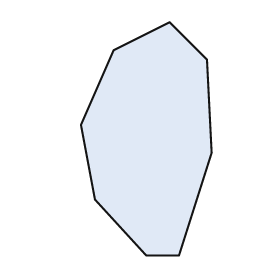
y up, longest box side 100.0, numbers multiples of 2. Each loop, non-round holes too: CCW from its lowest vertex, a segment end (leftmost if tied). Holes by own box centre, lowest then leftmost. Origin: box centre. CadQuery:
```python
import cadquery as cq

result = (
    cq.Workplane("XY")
    .moveTo(0.0, -50.0)
    .lineTo(14.0, -50.0)
    .lineTo(28.0, -6.0)
    .lineTo(26.0, 34.0)
    .lineTo(10.0, 50.0)
    .lineTo(-14.0, 38.0)
    .lineTo(-28.0, 6.0)
    .lineTo(-22.0, -26.0)
    .close()
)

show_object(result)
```